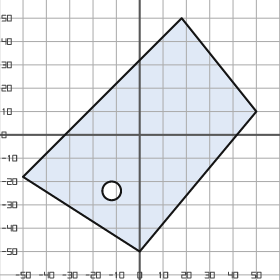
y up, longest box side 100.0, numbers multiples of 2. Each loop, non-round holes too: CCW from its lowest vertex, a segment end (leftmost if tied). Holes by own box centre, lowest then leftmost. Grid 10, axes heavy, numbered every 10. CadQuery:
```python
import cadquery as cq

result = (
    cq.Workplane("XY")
    .moveTo(0.0, -50.0)
    .lineTo(50.0, 10.0)
    .lineTo(18.0, 50.0)
    .lineTo(-50.0, -18.0)
    .close()
    .moveTo(-12.0, -24.0)
    .circle(4.0)
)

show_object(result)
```